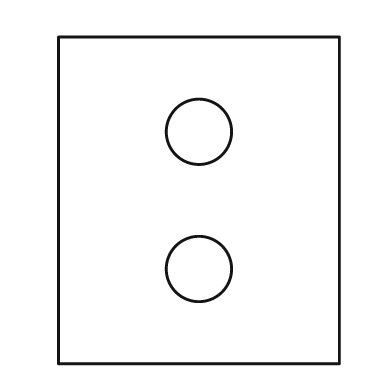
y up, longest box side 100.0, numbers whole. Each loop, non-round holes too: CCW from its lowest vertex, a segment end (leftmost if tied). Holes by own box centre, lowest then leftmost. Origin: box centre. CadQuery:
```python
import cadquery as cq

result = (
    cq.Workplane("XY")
    .moveTo(-43.0, -50.0)
    .lineTo(43.0, -50.0)
    .lineTo(43.0, 50.0)
    .lineTo(-43.0, 50.0)
    .close()
    .moveTo(0.0, -21.0)
    .circle(10.0)
    .moveTo(0.0, 21.0)
    .circle(10.0)
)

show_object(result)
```